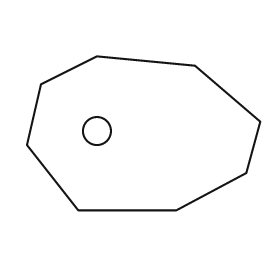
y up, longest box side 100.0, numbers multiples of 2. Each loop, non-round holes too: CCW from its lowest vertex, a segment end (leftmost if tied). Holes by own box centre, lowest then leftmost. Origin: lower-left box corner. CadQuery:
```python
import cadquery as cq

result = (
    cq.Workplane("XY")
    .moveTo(22.0, 0.0)
    .lineTo(64.0, 0.0)
    .lineTo(94.0, 16.0)
    .lineTo(100.0, 38.0)
    .lineTo(72.0, 62.0)
    .lineTo(30.0, 66.0)
    .lineTo(6.0, 54.0)
    .lineTo(0.0, 28.0)
    .close()
    .moveTo(30.0, 34.0)
    .circle(6.0)
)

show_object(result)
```